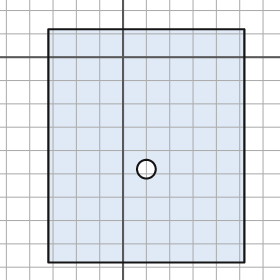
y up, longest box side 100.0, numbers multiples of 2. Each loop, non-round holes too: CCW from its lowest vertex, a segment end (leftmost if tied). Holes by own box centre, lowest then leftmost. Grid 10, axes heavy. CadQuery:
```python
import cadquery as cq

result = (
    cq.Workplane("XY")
    .moveTo(-32.0, -88.0)
    .lineTo(52.0, -88.0)
    .lineTo(52.0, 12.0)
    .lineTo(-32.0, 12.0)
    .close()
    .moveTo(10.0, -48.0)
    .circle(4.0)
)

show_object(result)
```